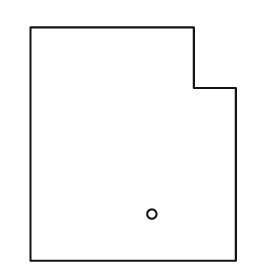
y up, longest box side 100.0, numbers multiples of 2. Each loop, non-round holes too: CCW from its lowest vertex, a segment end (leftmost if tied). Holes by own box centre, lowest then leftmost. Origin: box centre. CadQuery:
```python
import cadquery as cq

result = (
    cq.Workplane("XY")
    .moveTo(-44.0, -50.0)
    .lineTo(44.0, -50.0)
    .lineTo(44.0, 24.0)
    .lineTo(26.0, 24.0)
    .lineTo(26.0, 50.0)
    .lineTo(-44.0, 50.0)
    .close()
    .moveTo(8.0, -30.0)
    .circle(2.0)
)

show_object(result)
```